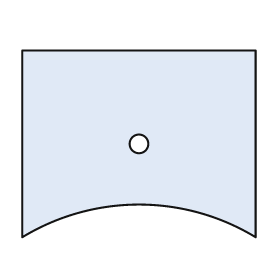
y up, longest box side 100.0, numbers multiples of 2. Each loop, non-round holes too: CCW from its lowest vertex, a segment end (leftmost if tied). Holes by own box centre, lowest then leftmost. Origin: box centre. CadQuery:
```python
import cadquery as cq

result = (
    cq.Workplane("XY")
    .moveTo(-50.0, -40.0)
    .threePointArc((0.0, -26.0), (50.0, -40.0))
    .lineTo(50.0, 40.0)
    .lineTo(-50.0, 40.0)
    .close()
    .moveTo(0.0, 0.0)
    .circle(4.0)
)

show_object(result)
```